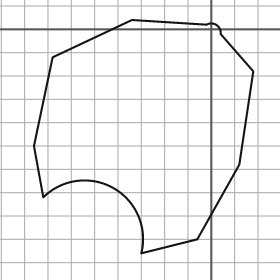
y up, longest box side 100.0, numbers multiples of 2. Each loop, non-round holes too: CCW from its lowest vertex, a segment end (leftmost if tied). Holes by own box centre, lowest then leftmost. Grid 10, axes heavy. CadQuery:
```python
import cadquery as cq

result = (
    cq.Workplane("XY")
    .moveTo(-30.0, -96.0)
    .lineTo(-6.0, -90.0)
    .lineTo(12.0, -58.0)
    .lineTo(18.0, -18.0)
    .lineTo(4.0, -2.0)
    .threePointArc((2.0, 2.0), (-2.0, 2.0))
    .lineTo(-34.0, 4.0)
    .lineTo(-68.0, -12.0)
    .lineTo(-76.0, -50.0)
    .lineTo(-72.0, -72.0)
    .threePointArc((-42.0, -68.0), (-30.0, -96.0))
    .close()
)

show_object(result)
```